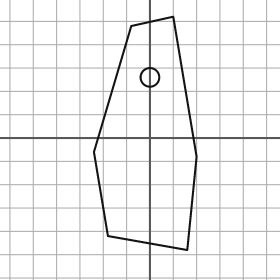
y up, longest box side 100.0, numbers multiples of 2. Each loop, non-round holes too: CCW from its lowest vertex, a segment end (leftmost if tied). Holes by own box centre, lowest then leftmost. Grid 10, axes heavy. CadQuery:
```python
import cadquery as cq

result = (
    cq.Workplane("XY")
    .moveTo(16.0, -48.0)
    .lineTo(20.0, -8.0)
    .lineTo(10.0, 52.0)
    .lineTo(-8.0, 48.0)
    .lineTo(-24.0, -6.0)
    .lineTo(-18.0, -42.0)
    .close()
    .moveTo(0.0, 26.0)
    .circle(4.0)
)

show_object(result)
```